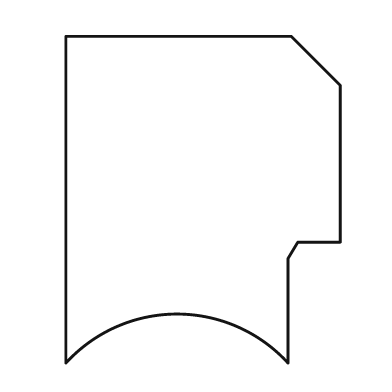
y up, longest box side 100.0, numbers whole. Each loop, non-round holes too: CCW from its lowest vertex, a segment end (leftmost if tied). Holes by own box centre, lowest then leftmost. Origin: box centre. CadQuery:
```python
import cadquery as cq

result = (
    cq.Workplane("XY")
    .moveTo(-42.0, -50.0)
    .threePointArc((-8.0, -35.0), (26.0, -50.0))
    .lineTo(26.0, -18.0)
    .lineTo(29.0, -13.0)
    .lineTo(42.0, -13.0)
    .lineTo(42.0, 35.0)
    .lineTo(27.0, 50.0)
    .lineTo(-42.0, 50.0)
    .close()
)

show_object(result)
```